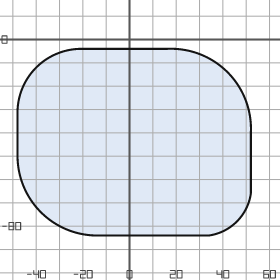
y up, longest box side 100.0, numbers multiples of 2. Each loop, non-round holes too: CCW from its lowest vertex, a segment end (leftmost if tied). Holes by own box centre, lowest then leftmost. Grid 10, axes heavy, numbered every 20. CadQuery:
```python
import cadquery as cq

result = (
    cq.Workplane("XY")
    .moveTo(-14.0, -84.0)
    .lineTo(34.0, -84.0)
    .threePointArc((46.0, -78.0), (52.0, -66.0))
    .lineTo(52.0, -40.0)
    .threePointArc((42.0, -14.0), (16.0, -4.0))
    .lineTo(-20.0, -4.0)
    .threePointArc((-40.0, -12.0), (-48.0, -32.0))
    .lineTo(-48.0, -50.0)
    .threePointArc((-38.0, -74.0), (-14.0, -84.0))
    .close()
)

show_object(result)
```